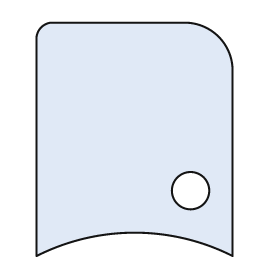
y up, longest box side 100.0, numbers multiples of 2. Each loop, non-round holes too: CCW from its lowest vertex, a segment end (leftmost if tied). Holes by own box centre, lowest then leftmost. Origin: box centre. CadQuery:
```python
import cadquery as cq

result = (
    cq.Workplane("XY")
    .moveTo(-42.0, -50.0)
    .threePointArc((0.0, -40.0), (42.0, -50.0))
    .lineTo(42.0, 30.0)
    .threePointArc((36.0, 44.0), (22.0, 50.0))
    .lineTo(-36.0, 50.0)
    .threePointArc((-40.0, 48.0), (-42.0, 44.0))
    .close()
    .moveTo(24.0, -22.0)
    .circle(8.0)
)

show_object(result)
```